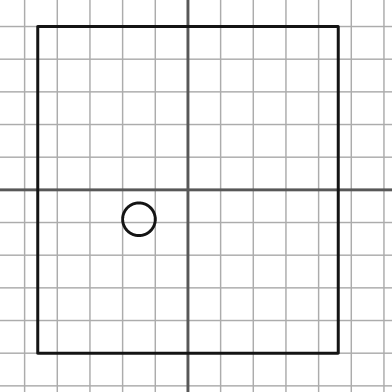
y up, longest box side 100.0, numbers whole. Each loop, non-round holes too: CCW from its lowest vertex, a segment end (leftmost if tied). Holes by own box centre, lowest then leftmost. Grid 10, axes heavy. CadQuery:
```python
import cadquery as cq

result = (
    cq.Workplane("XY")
    .moveTo(-46.0, -50.0)
    .lineTo(46.0, -50.0)
    .lineTo(46.0, 50.0)
    .lineTo(-46.0, 50.0)
    .close()
    .moveTo(-15.0, -9.0)
    .circle(5.0)
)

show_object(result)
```